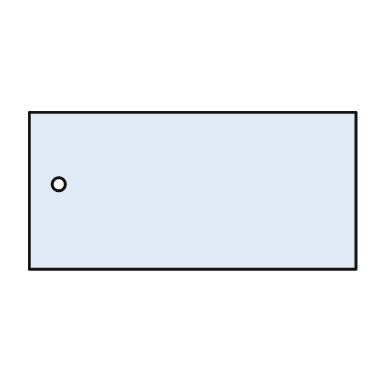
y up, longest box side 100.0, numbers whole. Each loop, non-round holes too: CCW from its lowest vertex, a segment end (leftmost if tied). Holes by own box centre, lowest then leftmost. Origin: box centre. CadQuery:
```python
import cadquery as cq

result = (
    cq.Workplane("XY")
    .moveTo(-50.0, -24.0)
    .lineTo(50.0, -24.0)
    .lineTo(50.0, 24.0)
    .lineTo(-50.0, 24.0)
    .close()
    .moveTo(-41.0, 2.0)
    .circle(2.0)
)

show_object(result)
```